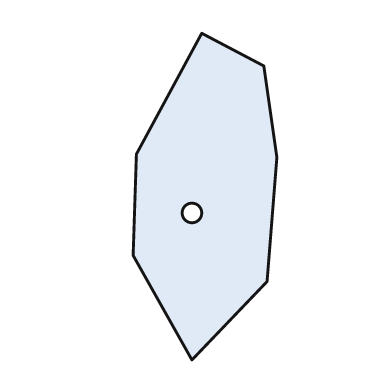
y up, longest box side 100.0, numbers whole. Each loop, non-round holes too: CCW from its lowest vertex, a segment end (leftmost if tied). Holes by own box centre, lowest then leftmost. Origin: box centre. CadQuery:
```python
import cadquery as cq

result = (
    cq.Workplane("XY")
    .moveTo(-4.0, -50.0)
    .lineTo(19.0, -26.0)
    .lineTo(22.0, 12.0)
    .lineTo(18.0, 40.0)
    .lineTo(-1.0, 50.0)
    .lineTo(-21.0, 13.0)
    .lineTo(-22.0, -18.0)
    .close()
    .moveTo(-4.0, -5.0)
    .circle(3.0)
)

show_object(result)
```